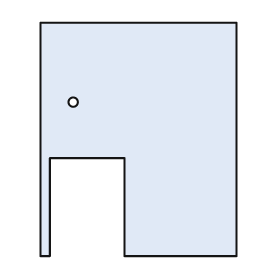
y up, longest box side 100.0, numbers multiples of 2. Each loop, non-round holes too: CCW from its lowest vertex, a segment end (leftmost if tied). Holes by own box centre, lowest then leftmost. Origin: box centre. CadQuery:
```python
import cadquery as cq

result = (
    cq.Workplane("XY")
    .moveTo(-42.0, -50.0)
    .lineTo(-38.0, -50.0)
    .lineTo(-38.0, -8.0)
    .lineTo(-6.0, -8.0)
    .lineTo(-6.0, -50.0)
    .lineTo(42.0, -50.0)
    .lineTo(42.0, 50.0)
    .lineTo(-42.0, 50.0)
    .close()
    .moveTo(-28.0, 16.0)
    .circle(2.0)
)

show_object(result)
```